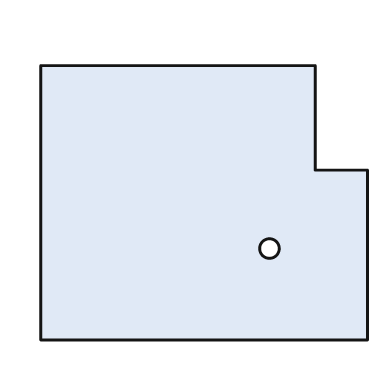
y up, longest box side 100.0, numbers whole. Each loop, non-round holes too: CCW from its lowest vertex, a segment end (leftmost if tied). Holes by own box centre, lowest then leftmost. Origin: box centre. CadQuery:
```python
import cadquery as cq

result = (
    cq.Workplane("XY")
    .moveTo(-50.0, -42.0)
    .lineTo(50.0, -42.0)
    .lineTo(50.0, 10.0)
    .lineTo(34.0, 10.0)
    .lineTo(34.0, 42.0)
    .lineTo(-50.0, 42.0)
    .close()
    .moveTo(20.0, -14.0)
    .circle(3.0)
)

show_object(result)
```